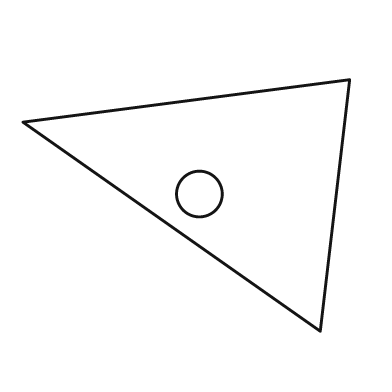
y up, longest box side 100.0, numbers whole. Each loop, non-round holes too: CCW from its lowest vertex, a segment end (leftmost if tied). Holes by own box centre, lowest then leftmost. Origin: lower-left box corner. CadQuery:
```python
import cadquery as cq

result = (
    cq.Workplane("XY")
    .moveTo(91.0, 0.0)
    .lineTo(100.0, 77.0)
    .lineTo(0.0, 64.0)
    .close()
    .moveTo(54.0, 42.0)
    .circle(7.0)
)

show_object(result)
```